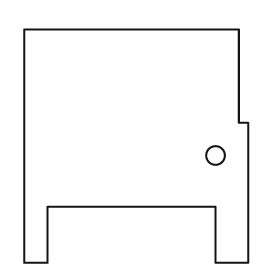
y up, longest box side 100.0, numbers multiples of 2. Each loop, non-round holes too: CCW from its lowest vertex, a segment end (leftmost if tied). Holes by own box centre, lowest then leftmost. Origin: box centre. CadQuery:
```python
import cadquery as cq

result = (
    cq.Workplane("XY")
    .moveTo(-48.0, -50.0)
    .lineTo(-38.0, -50.0)
    .lineTo(-38.0, -26.0)
    .lineTo(34.0, -26.0)
    .lineTo(34.0, -50.0)
    .lineTo(48.0, -50.0)
    .lineTo(48.0, 10.0)
    .lineTo(44.0, 10.0)
    .lineTo(44.0, 50.0)
    .lineTo(-48.0, 50.0)
    .close()
    .moveTo(34.0, -4.0)
    .circle(4.0)
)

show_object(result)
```